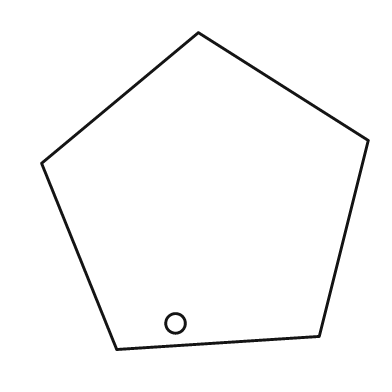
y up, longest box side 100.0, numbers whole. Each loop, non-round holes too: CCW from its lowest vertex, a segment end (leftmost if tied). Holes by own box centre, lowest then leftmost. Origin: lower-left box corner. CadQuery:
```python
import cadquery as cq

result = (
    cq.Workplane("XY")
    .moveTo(23.0, 0.0)
    .lineTo(85.0, 4.0)
    .lineTo(100.0, 64.0)
    .lineTo(48.0, 97.0)
    .lineTo(0.0, 57.0)
    .close()
    .moveTo(41.0, 8.0)
    .circle(3.0)
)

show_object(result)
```